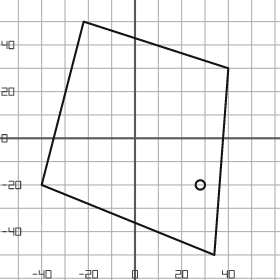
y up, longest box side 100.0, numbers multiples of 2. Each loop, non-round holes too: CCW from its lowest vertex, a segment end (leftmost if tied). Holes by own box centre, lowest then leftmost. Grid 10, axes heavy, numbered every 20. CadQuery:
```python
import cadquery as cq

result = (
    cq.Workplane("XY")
    .moveTo(34.0, -50.0)
    .lineTo(40.0, 30.0)
    .lineTo(-22.0, 50.0)
    .lineTo(-40.0, -20.0)
    .close()
    .moveTo(28.0, -20.0)
    .circle(2.0)
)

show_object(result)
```